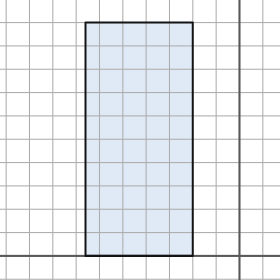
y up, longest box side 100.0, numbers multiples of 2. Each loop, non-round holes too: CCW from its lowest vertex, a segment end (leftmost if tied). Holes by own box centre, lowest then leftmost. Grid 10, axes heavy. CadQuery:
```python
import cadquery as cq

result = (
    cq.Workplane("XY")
    .moveTo(-66.0, 0.0)
    .lineTo(-20.0, 0.0)
    .lineTo(-20.0, 100.0)
    .lineTo(-66.0, 100.0)
    .close()
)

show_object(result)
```